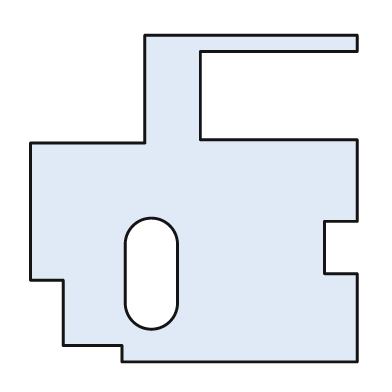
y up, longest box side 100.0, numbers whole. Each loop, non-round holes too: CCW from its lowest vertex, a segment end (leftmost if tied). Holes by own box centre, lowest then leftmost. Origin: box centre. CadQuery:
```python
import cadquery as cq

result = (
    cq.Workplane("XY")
    .moveTo(-22.0, -50.0)
    .lineTo(50.0, -50.0)
    .lineTo(50.0, -23.0)
    .lineTo(40.0, -23.0)
    .lineTo(40.0, -7.0)
    .lineTo(50.0, -7.0)
    .lineTo(50.0, 18.0)
    .lineTo(2.0, 18.0)
    .lineTo(2.0, 45.0)
    .lineTo(50.0, 45.0)
    .lineTo(50.0, 50.0)
    .lineTo(-15.0, 50.0)
    .lineTo(-15.0, 17.0)
    .lineTo(-50.0, 17.0)
    .lineTo(-50.0, -25.0)
    .lineTo(-40.0, -25.0)
    .lineTo(-40.0, -45.0)
    .lineTo(-22.0, -45.0)
    .close()
    .moveTo(-21.0, -32.0)
    .threePointArc((-13.0, -40.0), (-5.0, -32.0))
    .lineTo(-5.0, -14.0)
    .threePointArc((-13.0, -6.0), (-21.0, -14.0))
    .close()
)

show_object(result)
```